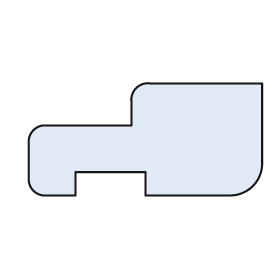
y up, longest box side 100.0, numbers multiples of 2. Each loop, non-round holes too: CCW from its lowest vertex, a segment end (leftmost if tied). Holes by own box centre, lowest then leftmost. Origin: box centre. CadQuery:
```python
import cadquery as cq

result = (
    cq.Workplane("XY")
    .moveTo(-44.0, -24.0)
    .lineTo(-30.0, -24.0)
    .lineTo(-30.0, -14.0)
    .lineTo(0.0, -14.0)
    .lineTo(0.0, -24.0)
    .lineTo(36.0, -24.0)
    .threePointArc((46.0, -20.0), (50.0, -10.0))
    .lineTo(50.0, 24.0)
    .lineTo(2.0, 24.0)
    .threePointArc((-4.0, 22.0), (-6.0, 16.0))
    .lineTo(-6.0, 6.0)
    .lineTo(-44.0, 6.0)
    .threePointArc((-48.0, 4.0), (-50.0, 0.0))
    .lineTo(-50.0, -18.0)
    .threePointArc((-48.0, -22.0), (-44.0, -24.0))
    .close()
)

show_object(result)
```